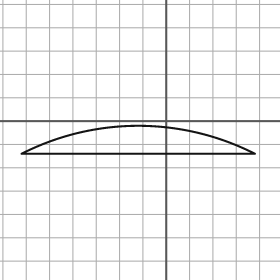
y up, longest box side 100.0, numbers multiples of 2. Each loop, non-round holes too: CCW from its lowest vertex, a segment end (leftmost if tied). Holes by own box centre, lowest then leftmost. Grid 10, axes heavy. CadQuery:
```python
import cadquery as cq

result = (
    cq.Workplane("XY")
    .moveTo(-62.0, -14.0)
    .lineTo(38.0, -14.0)
    .threePointArc((-12.0, -2.0), (-62.0, -14.0))
    .close()
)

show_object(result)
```